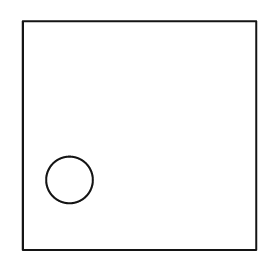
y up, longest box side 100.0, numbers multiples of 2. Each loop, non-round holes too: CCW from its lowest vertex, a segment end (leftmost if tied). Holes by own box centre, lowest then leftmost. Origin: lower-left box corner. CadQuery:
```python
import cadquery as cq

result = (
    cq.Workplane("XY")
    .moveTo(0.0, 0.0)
    .lineTo(100.0, 0.0)
    .lineTo(100.0, 98.0)
    .lineTo(0.0, 98.0)
    .close()
    .moveTo(20.0, 30.0)
    .circle(10.0)
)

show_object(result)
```